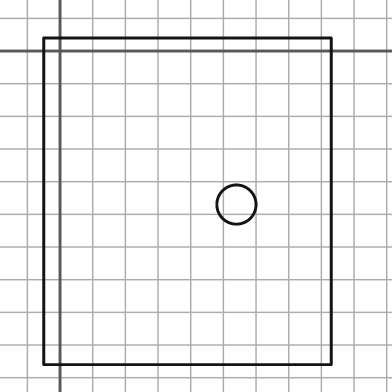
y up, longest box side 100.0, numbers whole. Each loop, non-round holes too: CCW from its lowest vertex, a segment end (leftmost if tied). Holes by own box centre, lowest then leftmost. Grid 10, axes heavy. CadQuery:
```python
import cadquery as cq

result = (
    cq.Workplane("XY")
    .moveTo(-5.0, -96.0)
    .lineTo(83.0, -96.0)
    .lineTo(83.0, 4.0)
    .lineTo(-5.0, 4.0)
    .close()
    .moveTo(54.0, -47.0)
    .circle(6.0)
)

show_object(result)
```